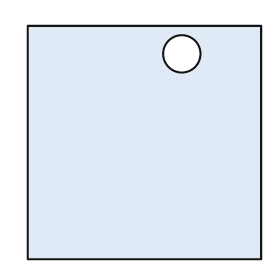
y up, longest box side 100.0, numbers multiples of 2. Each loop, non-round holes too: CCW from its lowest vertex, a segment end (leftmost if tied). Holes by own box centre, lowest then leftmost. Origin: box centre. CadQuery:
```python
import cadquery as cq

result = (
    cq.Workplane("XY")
    .moveTo(-50.0, -50.0)
    .lineTo(50.0, -50.0)
    .lineTo(50.0, 50.0)
    .lineTo(-50.0, 50.0)
    .close()
    .moveTo(16.0, 38.0)
    .circle(8.0)
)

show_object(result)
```